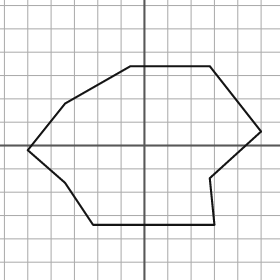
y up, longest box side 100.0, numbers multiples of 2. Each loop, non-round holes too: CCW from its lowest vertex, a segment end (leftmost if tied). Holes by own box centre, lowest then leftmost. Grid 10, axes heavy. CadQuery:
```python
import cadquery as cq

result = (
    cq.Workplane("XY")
    .moveTo(-22.0, -34.0)
    .lineTo(30.0, -34.0)
    .lineTo(28.0, -14.0)
    .lineTo(50.0, 6.0)
    .lineTo(28.0, 34.0)
    .lineTo(-6.0, 34.0)
    .lineTo(-34.0, 18.0)
    .lineTo(-50.0, -2.0)
    .lineTo(-34.0, -16.0)
    .close()
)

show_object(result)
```